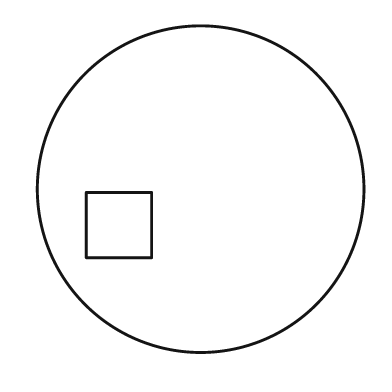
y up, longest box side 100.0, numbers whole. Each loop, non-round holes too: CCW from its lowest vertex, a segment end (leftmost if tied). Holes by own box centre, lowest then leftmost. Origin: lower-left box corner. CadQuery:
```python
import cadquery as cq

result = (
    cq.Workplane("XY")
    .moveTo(50.0, 50.0)
    .circle(50.0)
    .moveTo(15.0, 29.0)
    .lineTo(35.0, 29.0)
    .lineTo(35.0, 49.0)
    .lineTo(15.0, 49.0)
    .close()
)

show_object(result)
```